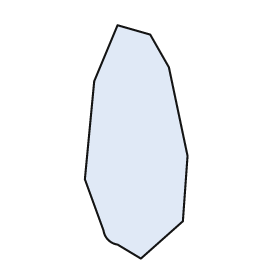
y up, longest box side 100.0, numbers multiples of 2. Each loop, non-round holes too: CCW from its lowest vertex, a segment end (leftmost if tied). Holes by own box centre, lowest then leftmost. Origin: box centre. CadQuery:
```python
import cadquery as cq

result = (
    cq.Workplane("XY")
    .moveTo(2.0, -50.0)
    .lineTo(20.0, -34.0)
    .lineTo(22.0, -6.0)
    .lineTo(14.0, 32.0)
    .lineTo(6.0, 46.0)
    .lineTo(-8.0, 50.0)
    .lineTo(-18.0, 26.0)
    .lineTo(-22.0, -16.0)
    .lineTo(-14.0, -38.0)
    .threePointArc((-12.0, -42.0), (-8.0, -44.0))
    .close()
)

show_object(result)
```